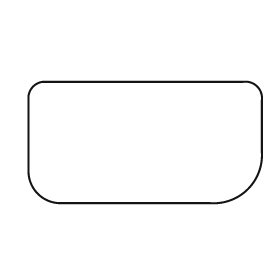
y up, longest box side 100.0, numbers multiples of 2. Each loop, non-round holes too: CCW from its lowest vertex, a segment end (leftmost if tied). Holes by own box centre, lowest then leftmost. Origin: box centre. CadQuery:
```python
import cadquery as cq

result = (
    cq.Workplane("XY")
    .moveTo(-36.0, -26.0)
    .lineTo(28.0, -26.0)
    .threePointArc((44.0, -20.0), (50.0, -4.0))
    .lineTo(50.0, 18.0)
    .threePointArc((48.0, 24.0), (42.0, 26.0))
    .lineTo(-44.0, 26.0)
    .threePointArc((-48.0, 24.0), (-50.0, 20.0))
    .lineTo(-50.0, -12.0)
    .threePointArc((-46.0, -22.0), (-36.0, -26.0))
    .close()
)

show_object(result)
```